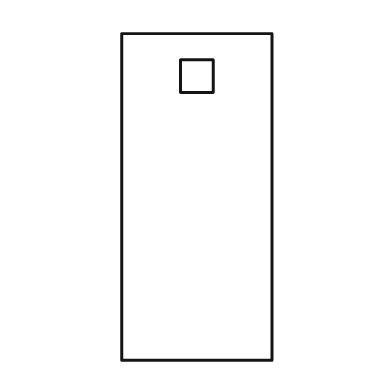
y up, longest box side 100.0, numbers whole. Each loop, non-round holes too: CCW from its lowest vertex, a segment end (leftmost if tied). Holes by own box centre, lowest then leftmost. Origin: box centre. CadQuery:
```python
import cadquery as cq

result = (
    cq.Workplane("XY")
    .moveTo(-23.0, -50.0)
    .lineTo(23.0, -50.0)
    .lineTo(23.0, 50.0)
    .lineTo(-23.0, 50.0)
    .close()
    .moveTo(-5.0, 32.0)
    .lineTo(5.0, 32.0)
    .lineTo(5.0, 42.0)
    .lineTo(-5.0, 42.0)
    .close()
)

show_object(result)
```